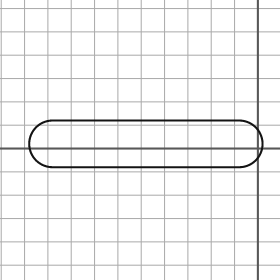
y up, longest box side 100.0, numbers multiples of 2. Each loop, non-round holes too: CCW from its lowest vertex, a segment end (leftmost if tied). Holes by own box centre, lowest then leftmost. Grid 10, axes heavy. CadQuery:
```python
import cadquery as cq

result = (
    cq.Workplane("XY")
    .moveTo(-88.0, -8.0)
    .lineTo(-8.0, -8.0)
    .threePointArc((2.0, 2.0), (-8.0, 12.0))
    .lineTo(-88.0, 12.0)
    .threePointArc((-98.0, 2.0), (-88.0, -8.0))
    .close()
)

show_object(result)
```